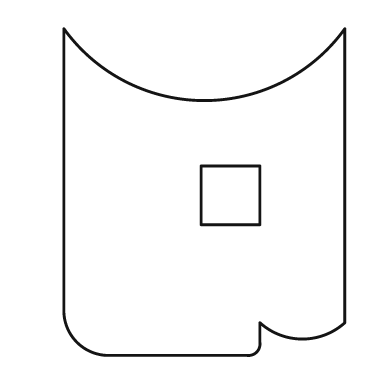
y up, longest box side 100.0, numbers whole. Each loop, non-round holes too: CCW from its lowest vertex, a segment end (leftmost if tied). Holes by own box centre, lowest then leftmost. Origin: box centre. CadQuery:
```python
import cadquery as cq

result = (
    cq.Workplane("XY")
    .moveTo(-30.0, -50.0)
    .lineTo(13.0, -50.0)
    .threePointArc((16.0, -49.0), (17.0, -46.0))
    .lineTo(17.0, -40.0)
    .threePointArc((30.0, -45.0), (43.0, -40.0))
    .lineTo(43.0, 50.0)
    .threePointArc((0.0, 28.0), (-43.0, 50.0))
    .lineTo(-43.0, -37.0)
    .threePointArc((-39.0, -46.0), (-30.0, -50.0))
    .close()
    .moveTo(-1.0, -10.0)
    .lineTo(17.0, -10.0)
    .lineTo(17.0, 8.0)
    .lineTo(-1.0, 8.0)
    .close()
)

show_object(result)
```